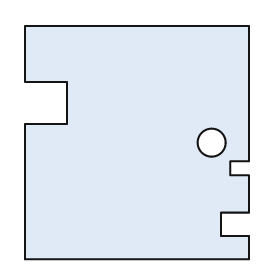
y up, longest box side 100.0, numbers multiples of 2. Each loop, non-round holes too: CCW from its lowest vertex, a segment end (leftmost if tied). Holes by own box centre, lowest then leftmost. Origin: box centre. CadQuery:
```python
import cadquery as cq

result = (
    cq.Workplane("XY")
    .moveTo(-48.0, -50.0)
    .lineTo(48.0, -50.0)
    .lineTo(48.0, -40.0)
    .lineTo(36.0, -40.0)
    .lineTo(36.0, -30.0)
    .lineTo(48.0, -30.0)
    .lineTo(48.0, -14.0)
    .lineTo(40.0, -14.0)
    .lineTo(40.0, -8.0)
    .lineTo(48.0, -8.0)
    .lineTo(48.0, 50.0)
    .lineTo(-48.0, 50.0)
    .lineTo(-48.0, 26.0)
    .lineTo(-30.0, 26.0)
    .lineTo(-30.0, 8.0)
    .lineTo(-48.0, 8.0)
    .close()
    .moveTo(32.0, 0.0)
    .circle(6.0)
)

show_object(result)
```